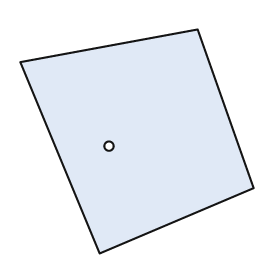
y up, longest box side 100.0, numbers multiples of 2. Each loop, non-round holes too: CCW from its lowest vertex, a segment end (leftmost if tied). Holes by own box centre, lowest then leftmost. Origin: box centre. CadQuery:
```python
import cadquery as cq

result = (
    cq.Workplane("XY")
    .moveTo(-16.0, -48.0)
    .lineTo(50.0, -20.0)
    .lineTo(26.0, 48.0)
    .lineTo(-50.0, 34.0)
    .close()
    .moveTo(-12.0, -2.0)
    .circle(2.0)
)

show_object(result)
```